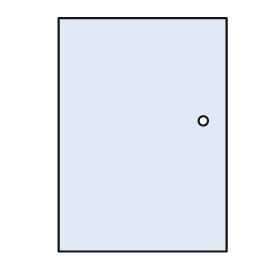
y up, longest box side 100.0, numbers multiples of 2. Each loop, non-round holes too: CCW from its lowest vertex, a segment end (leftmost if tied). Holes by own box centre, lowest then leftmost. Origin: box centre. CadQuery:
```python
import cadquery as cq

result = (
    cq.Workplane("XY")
    .moveTo(-36.0, -50.0)
    .lineTo(36.0, -50.0)
    .lineTo(36.0, 50.0)
    .lineTo(-36.0, 50.0)
    .close()
    .moveTo(26.0, 6.0)
    .circle(2.0)
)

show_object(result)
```